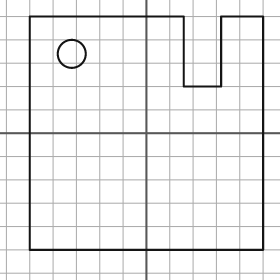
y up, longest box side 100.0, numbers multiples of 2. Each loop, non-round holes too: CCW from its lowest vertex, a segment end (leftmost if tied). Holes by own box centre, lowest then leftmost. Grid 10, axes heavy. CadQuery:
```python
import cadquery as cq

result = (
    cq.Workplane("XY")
    .moveTo(-50.0, -50.0)
    .lineTo(50.0, -50.0)
    .lineTo(50.0, 50.0)
    .lineTo(32.0, 50.0)
    .lineTo(32.0, 20.0)
    .lineTo(16.0, 20.0)
    .lineTo(16.0, 50.0)
    .lineTo(-50.0, 50.0)
    .close()
    .moveTo(-32.0, 34.0)
    .circle(6.0)
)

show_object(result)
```